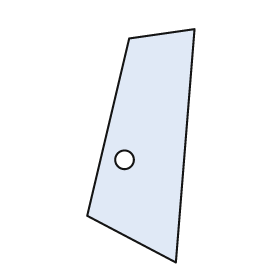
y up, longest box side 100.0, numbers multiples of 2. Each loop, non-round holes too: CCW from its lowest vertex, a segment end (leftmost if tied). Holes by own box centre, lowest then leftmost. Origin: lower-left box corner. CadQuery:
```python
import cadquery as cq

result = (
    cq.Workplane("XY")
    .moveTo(38.0, 0.0)
    .lineTo(46.0, 100.0)
    .lineTo(18.0, 96.0)
    .lineTo(0.0, 20.0)
    .close()
    .moveTo(16.0, 44.0)
    .circle(4.0)
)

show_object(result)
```